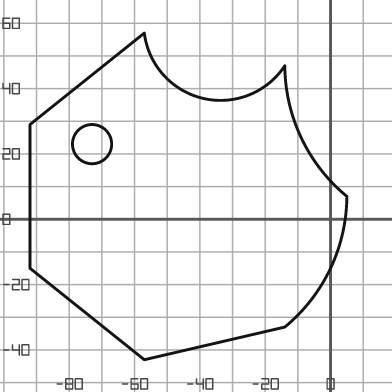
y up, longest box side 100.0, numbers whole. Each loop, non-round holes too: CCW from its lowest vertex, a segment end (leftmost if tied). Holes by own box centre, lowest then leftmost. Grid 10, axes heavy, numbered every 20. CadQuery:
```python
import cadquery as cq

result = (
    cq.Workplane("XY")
    .moveTo(-57.0, -43.0)
    .lineTo(-14.0, -33.0)
    .threePointArc((0.0, -15.0), (5.0, 7.0))
    .threePointArc((-9.0, 25.0), (-14.0, 47.0))
    .threePointArc((-39.0, 37.0), (-57.0, 57.0))
    .lineTo(-92.0, 29.0)
    .lineTo(-92.0, -15.0)
    .close()
    .moveTo(-73.0, 23.0)
    .circle(6.0)
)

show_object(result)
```